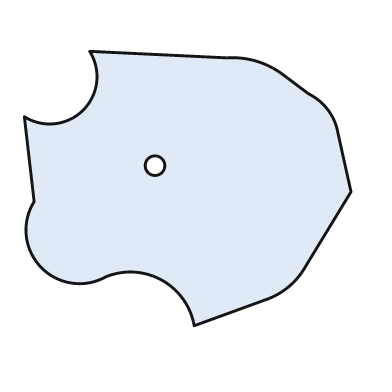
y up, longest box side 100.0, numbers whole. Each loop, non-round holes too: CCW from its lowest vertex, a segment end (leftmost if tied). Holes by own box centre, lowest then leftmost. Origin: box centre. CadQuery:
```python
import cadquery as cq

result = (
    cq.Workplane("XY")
    .moveTo(2.0, -42.0)
    .lineTo(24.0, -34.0)
    .threePointArc((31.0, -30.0), (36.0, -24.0))
    .lineTo(50.0, -1.0)
    .lineTo(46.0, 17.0)
    .threePointArc((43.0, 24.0), (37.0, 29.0))
    .lineTo(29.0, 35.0)
    .threePointArc((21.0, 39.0), (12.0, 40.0))
    .lineTo(-30.0, 42.0)
    .threePointArc((-32.0, 24.0), (-50.0, 22.0))
    .lineTo(-47.0, -4.0)
    .threePointArc((-45.0, -24.0), (-25.0, -27.0))
    .threePointArc((-8.0, -28.0), (2.0, -42.0))
    .close()
    .moveTo(-10.0, 7.0)
    .circle(3.0)
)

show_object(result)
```